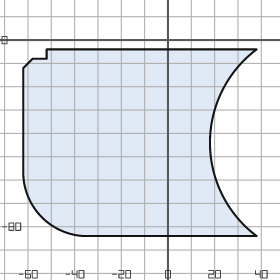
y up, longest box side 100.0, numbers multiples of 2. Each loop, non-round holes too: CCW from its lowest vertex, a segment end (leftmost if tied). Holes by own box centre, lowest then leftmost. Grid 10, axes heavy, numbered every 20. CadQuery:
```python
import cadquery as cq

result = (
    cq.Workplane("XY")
    .moveTo(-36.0, -84.0)
    .lineTo(38.0, -84.0)
    .threePointArc((18.0, -44.0), (38.0, -4.0))
    .lineTo(-52.0, -4.0)
    .lineTo(-52.0, -8.0)
    .lineTo(-58.0, -8.0)
    .lineTo(-62.0, -12.0)
    .lineTo(-62.0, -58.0)
    .threePointArc((-54.0, -76.0), (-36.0, -84.0))
    .close()
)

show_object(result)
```